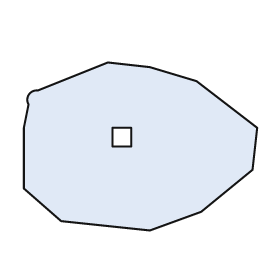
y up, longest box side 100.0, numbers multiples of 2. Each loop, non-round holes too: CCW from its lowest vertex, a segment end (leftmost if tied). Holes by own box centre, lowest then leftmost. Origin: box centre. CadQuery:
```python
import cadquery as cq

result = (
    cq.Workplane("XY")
    .moveTo(4.0, -36.0)
    .lineTo(26.0, -28.0)
    .lineTo(48.0, -10.0)
    .lineTo(50.0, 8.0)
    .lineTo(24.0, 28.0)
    .lineTo(4.0, 34.0)
    .lineTo(-14.0, 36.0)
    .lineTo(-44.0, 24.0)
    .threePointArc((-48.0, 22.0), (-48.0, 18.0))
    .lineTo(-50.0, 8.0)
    .lineTo(-50.0, -18.0)
    .lineTo(-34.0, -32.0)
    .close()
    .moveTo(-12.0, 0.0)
    .lineTo(-4.0, 0.0)
    .lineTo(-4.0, 8.0)
    .lineTo(-12.0, 8.0)
    .close()
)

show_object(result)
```